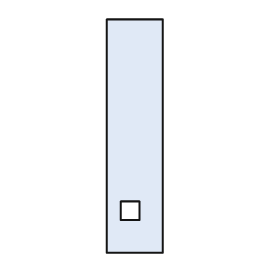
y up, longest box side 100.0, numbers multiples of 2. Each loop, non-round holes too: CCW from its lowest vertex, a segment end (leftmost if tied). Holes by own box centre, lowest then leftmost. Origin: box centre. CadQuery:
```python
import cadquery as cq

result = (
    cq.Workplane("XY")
    .moveTo(-12.0, -50.0)
    .lineTo(12.0, -50.0)
    .lineTo(12.0, 50.0)
    .lineTo(-12.0, 50.0)
    .close()
    .moveTo(-6.0, -36.0)
    .lineTo(2.0, -36.0)
    .lineTo(2.0, -28.0)
    .lineTo(-6.0, -28.0)
    .close()
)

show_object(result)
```